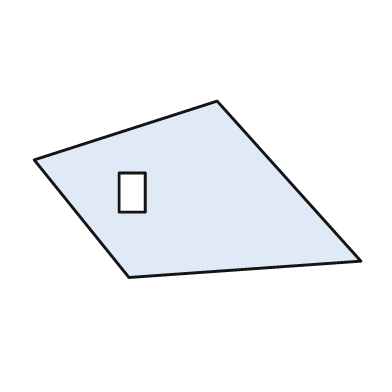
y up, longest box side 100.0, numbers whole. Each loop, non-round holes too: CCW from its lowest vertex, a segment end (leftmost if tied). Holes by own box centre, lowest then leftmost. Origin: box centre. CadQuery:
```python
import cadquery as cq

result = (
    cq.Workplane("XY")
    .moveTo(-21.0, -27.0)
    .lineTo(50.0, -22.0)
    .lineTo(6.0, 27.0)
    .lineTo(-50.0, 9.0)
    .close()
    .moveTo(-24.0, -7.0)
    .lineTo(-16.0, -7.0)
    .lineTo(-16.0, 5.0)
    .lineTo(-24.0, 5.0)
    .close()
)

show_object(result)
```